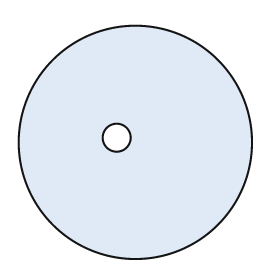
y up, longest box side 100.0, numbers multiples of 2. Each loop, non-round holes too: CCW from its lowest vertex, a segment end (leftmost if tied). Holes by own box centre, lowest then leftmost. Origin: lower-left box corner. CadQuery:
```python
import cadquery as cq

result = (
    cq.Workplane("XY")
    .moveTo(50.0, 50.0)
    .circle(50.0)
    .moveTo(42.0, 52.0)
    .circle(6.0)
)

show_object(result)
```